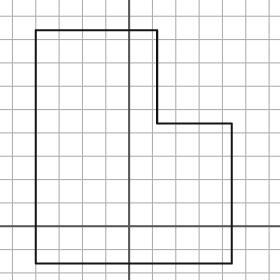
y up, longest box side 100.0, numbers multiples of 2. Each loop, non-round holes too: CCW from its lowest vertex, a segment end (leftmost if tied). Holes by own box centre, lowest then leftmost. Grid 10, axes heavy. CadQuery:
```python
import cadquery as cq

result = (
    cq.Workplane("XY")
    .moveTo(-40.0, -16.0)
    .lineTo(44.0, -16.0)
    .lineTo(44.0, 44.0)
    .lineTo(12.0, 44.0)
    .lineTo(12.0, 84.0)
    .lineTo(-40.0, 84.0)
    .close()
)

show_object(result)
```